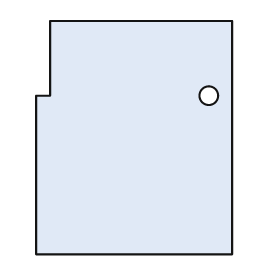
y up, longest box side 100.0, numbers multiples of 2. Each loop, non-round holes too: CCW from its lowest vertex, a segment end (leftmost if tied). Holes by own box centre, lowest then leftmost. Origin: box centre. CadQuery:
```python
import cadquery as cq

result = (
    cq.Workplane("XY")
    .moveTo(-42.0, -50.0)
    .lineTo(42.0, -50.0)
    .lineTo(42.0, 50.0)
    .lineTo(-36.0, 50.0)
    .lineTo(-36.0, 18.0)
    .lineTo(-42.0, 18.0)
    .close()
    .moveTo(32.0, 18.0)
    .circle(4.0)
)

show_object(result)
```